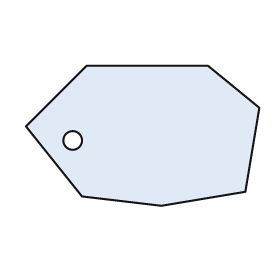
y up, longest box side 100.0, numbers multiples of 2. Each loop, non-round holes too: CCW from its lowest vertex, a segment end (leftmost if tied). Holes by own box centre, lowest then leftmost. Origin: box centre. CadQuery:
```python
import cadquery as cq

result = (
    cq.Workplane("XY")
    .moveTo(8.0, -30.0)
    .lineTo(44.0, -24.0)
    .lineTo(50.0, 12.0)
    .lineTo(28.0, 30.0)
    .lineTo(-24.0, 30.0)
    .lineTo(-50.0, 4.0)
    .lineTo(-26.0, -26.0)
    .close()
    .moveTo(-30.0, -2.0)
    .circle(4.0)
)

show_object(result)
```